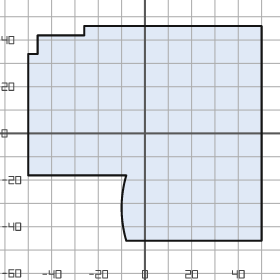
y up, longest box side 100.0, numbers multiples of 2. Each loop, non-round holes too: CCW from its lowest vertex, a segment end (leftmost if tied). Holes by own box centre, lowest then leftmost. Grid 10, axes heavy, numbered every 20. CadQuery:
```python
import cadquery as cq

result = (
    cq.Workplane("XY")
    .moveTo(-8.0, -46.0)
    .lineTo(50.0, -46.0)
    .lineTo(50.0, 46.0)
    .lineTo(-26.0, 46.0)
    .lineTo(-26.0, 42.0)
    .lineTo(-46.0, 42.0)
    .lineTo(-46.0, 34.0)
    .lineTo(-50.0, 34.0)
    .lineTo(-50.0, -18.0)
    .lineTo(-8.0, -18.0)
    .threePointArc((-10.0, -32.0), (-8.0, -46.0))
    .close()
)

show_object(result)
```